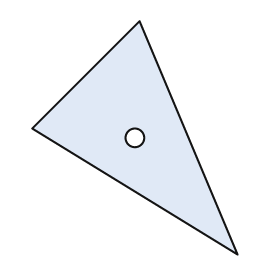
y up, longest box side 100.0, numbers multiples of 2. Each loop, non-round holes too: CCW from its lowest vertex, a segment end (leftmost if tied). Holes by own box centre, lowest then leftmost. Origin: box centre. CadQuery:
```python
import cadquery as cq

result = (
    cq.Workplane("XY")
    .moveTo(44.0, -50.0)
    .lineTo(2.0, 50.0)
    .lineTo(-44.0, 4.0)
    .close()
    .moveTo(0.0, 0.0)
    .circle(4.0)
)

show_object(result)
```